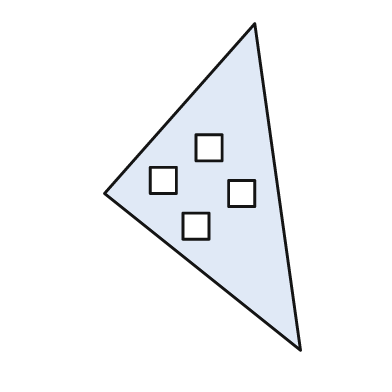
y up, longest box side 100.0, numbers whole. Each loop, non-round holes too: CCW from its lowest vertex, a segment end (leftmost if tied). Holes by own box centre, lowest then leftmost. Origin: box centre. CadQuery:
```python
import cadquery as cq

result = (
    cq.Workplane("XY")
    .moveTo(30.0, -50.0)
    .lineTo(16.0, 50.0)
    .lineTo(-30.0, -2.0)
    .close()
    .moveTo(-6.0, -16.0)
    .lineTo(2.0, -16.0)
    .lineTo(2.0, -8.0)
    .lineTo(-6.0, -8.0)
    .close()
    .moveTo(8.0, -6.0)
    .lineTo(16.0, -6.0)
    .lineTo(16.0, 2.0)
    .lineTo(8.0, 2.0)
    .close()
    .moveTo(-16.0, -2.0)
    .lineTo(-8.0, -2.0)
    .lineTo(-8.0, 6.0)
    .lineTo(-16.0, 6.0)
    .close()
    .moveTo(-2.0, 8.0)
    .lineTo(6.0, 8.0)
    .lineTo(6.0, 16.0)
    .lineTo(-2.0, 16.0)
    .close()
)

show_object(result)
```